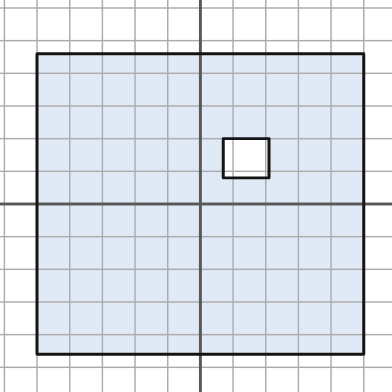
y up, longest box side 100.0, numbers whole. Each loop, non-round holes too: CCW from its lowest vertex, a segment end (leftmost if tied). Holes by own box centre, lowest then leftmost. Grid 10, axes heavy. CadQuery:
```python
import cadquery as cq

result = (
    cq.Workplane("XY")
    .moveTo(-50.0, -46.0)
    .lineTo(50.0, -46.0)
    .lineTo(50.0, 46.0)
    .lineTo(-50.0, 46.0)
    .close()
    .moveTo(7.0, 8.0)
    .lineTo(21.0, 8.0)
    .lineTo(21.0, 20.0)
    .lineTo(7.0, 20.0)
    .close()
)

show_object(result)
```